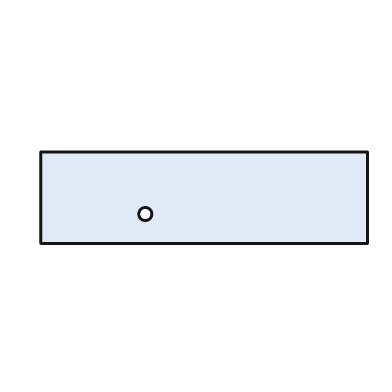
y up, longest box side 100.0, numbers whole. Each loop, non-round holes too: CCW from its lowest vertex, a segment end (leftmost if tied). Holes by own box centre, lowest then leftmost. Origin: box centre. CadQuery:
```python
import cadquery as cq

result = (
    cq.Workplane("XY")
    .moveTo(-50.0, -14.0)
    .lineTo(50.0, -14.0)
    .lineTo(50.0, 14.0)
    .lineTo(-50.0, 14.0)
    .close()
    .moveTo(-18.0, -5.0)
    .circle(2.0)
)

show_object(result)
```